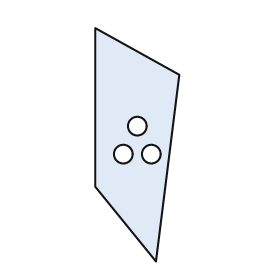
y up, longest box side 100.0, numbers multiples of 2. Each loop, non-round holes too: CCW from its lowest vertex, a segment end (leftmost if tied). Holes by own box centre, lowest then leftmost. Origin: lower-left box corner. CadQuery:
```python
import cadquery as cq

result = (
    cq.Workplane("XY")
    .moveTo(26.0, 0.0)
    .lineTo(36.0, 80.0)
    .lineTo(0.0, 100.0)
    .lineTo(0.0, 32.0)
    .close()
    .moveTo(12.0, 46.0)
    .circle(4.0)
    .moveTo(24.0, 46.0)
    .circle(4.0)
    .moveTo(18.0, 58.0)
    .circle(4.0)
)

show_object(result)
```